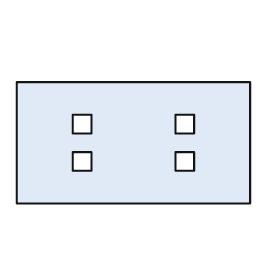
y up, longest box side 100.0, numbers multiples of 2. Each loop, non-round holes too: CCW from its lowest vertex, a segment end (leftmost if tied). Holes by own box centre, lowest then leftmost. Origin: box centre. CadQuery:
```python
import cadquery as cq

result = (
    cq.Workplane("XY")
    .moveTo(-50.0, -26.0)
    .lineTo(50.0, -26.0)
    .lineTo(50.0, 26.0)
    .lineTo(-50.0, 26.0)
    .close()
    .moveTo(-26.0, -12.0)
    .lineTo(-18.0, -12.0)
    .lineTo(-18.0, -4.0)
    .lineTo(-26.0, -4.0)
    .close()
    .moveTo(18.0, -12.0)
    .lineTo(26.0, -12.0)
    .lineTo(26.0, -4.0)
    .lineTo(18.0, -4.0)
    .close()
    .moveTo(-26.0, 4.0)
    .lineTo(-18.0, 4.0)
    .lineTo(-18.0, 12.0)
    .lineTo(-26.0, 12.0)
    .close()
    .moveTo(18.0, 4.0)
    .lineTo(26.0, 4.0)
    .lineTo(26.0, 12.0)
    .lineTo(18.0, 12.0)
    .close()
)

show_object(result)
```